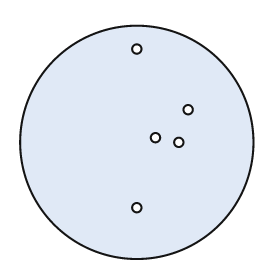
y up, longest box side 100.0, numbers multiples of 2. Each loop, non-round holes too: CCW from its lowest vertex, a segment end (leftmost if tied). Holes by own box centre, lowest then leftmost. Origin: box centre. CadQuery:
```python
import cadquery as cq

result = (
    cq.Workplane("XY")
    .moveTo(0.0, 0.0)
    .circle(50.0)
    .moveTo(0.0, -28.0)
    .circle(2.0)
    .moveTo(18.0, 0.0)
    .circle(2.0)
    .moveTo(8.0, 2.0)
    .circle(2.0)
    .moveTo(22.0, 14.0)
    .circle(2.0)
    .moveTo(0.0, 40.0)
    .circle(2.0)
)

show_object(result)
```